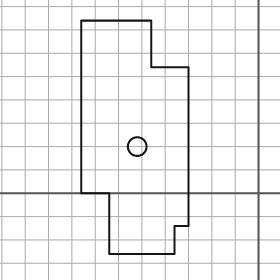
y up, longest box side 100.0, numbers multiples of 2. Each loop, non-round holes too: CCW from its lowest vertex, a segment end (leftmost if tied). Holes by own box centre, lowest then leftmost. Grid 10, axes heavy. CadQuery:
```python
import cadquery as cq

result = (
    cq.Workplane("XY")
    .moveTo(-64.0, -26.0)
    .lineTo(-36.0, -26.0)
    .lineTo(-36.0, -14.0)
    .lineTo(-30.0, -14.0)
    .lineTo(-30.0, 54.0)
    .lineTo(-46.0, 54.0)
    .lineTo(-46.0, 74.0)
    .lineTo(-76.0, 74.0)
    .lineTo(-76.0, 0.0)
    .lineTo(-64.0, 0.0)
    .close()
    .moveTo(-52.0, 20.0)
    .circle(4.0)
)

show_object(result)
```